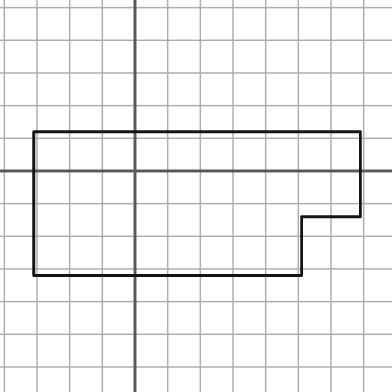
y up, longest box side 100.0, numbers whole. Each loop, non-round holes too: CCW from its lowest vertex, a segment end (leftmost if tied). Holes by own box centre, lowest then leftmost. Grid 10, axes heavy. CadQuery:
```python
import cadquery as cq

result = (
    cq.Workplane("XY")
    .moveTo(-31.0, -32.0)
    .lineTo(51.0, -32.0)
    .lineTo(51.0, -14.0)
    .lineTo(69.0, -14.0)
    .lineTo(69.0, 12.0)
    .lineTo(-31.0, 12.0)
    .close()
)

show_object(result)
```